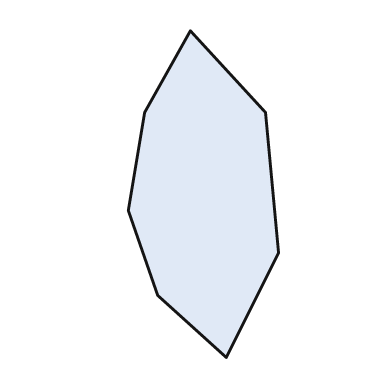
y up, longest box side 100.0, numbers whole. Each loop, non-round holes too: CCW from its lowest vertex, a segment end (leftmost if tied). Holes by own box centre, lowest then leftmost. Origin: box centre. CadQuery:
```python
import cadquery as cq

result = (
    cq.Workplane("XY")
    .moveTo(7.0, -50.0)
    .lineTo(23.0, -18.0)
    .lineTo(19.0, 25.0)
    .lineTo(-4.0, 50.0)
    .lineTo(-18.0, 25.0)
    .lineTo(-23.0, -5.0)
    .lineTo(-14.0, -31.0)
    .close()
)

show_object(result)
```